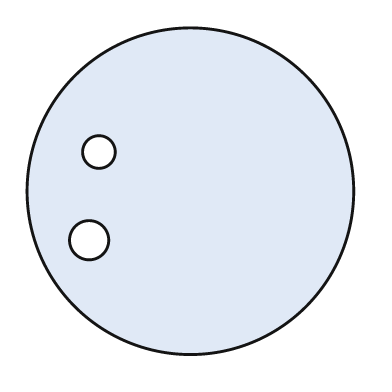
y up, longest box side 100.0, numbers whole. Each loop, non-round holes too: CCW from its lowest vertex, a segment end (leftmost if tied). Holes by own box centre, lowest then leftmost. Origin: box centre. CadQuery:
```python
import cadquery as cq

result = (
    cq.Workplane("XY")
    .moveTo(0.0, 0.0)
    .circle(50.0)
    .moveTo(-31.0, -15.0)
    .circle(6.0)
    .moveTo(-28.0, 12.0)
    .circle(5.0)
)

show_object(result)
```